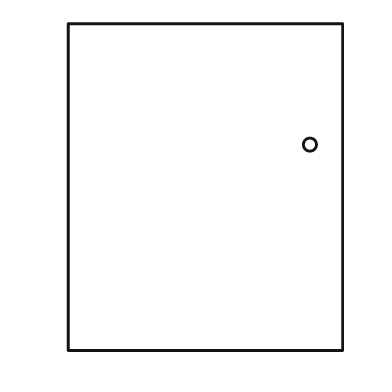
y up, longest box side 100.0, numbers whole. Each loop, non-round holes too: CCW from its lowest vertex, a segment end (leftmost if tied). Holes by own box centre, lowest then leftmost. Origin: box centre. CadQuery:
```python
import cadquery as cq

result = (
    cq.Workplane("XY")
    .moveTo(-42.0, -50.0)
    .lineTo(42.0, -50.0)
    .lineTo(42.0, 50.0)
    .lineTo(-42.0, 50.0)
    .close()
    .moveTo(32.0, 13.0)
    .circle(2.0)
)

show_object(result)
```